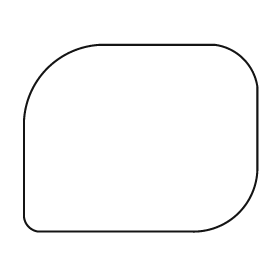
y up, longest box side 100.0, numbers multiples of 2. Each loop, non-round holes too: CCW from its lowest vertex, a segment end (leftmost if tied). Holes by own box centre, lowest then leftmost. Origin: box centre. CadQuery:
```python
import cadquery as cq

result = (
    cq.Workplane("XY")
    .moveTo(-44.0, -40.0)
    .lineTo(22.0, -40.0)
    .threePointArc((42.0, -32.0), (50.0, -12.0))
    .lineTo(50.0, 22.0)
    .threePointArc((44.0, 34.0), (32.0, 40.0))
    .lineTo(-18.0, 40.0)
    .threePointArc((-40.0, 30.0), (-50.0, 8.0))
    .lineTo(-50.0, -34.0)
    .threePointArc((-48.0, -38.0), (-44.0, -40.0))
    .close()
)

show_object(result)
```